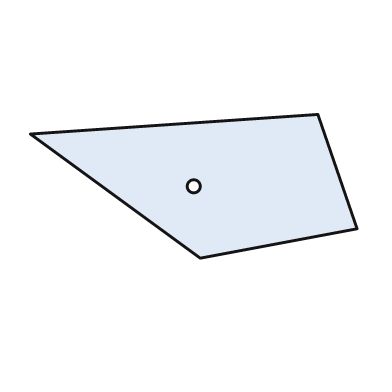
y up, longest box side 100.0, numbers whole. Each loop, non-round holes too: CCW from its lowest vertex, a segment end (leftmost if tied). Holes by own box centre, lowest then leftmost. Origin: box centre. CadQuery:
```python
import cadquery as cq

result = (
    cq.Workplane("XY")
    .moveTo(2.0, -22.0)
    .lineTo(50.0, -13.0)
    .lineTo(38.0, 22.0)
    .lineTo(-50.0, 16.0)
    .close()
    .moveTo(0.0, 0.0)
    .circle(2.0)
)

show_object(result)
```